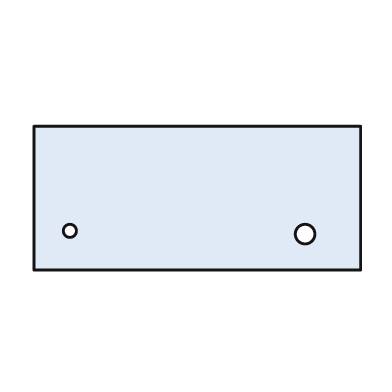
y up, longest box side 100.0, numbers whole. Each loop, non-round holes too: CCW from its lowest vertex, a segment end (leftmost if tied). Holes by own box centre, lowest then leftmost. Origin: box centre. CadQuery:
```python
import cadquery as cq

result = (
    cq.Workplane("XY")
    .moveTo(-50.0, -22.0)
    .lineTo(50.0, -22.0)
    .lineTo(50.0, 22.0)
    .lineTo(-50.0, 22.0)
    .close()
    .moveTo(33.0, -11.0)
    .circle(3.0)
    .moveTo(-39.0, -10.0)
    .circle(2.0)
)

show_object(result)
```